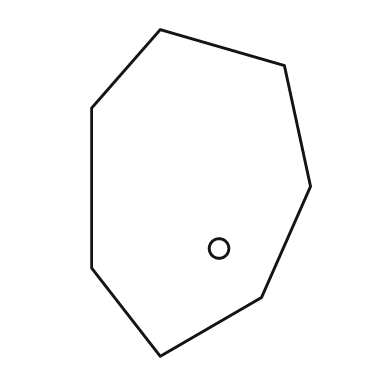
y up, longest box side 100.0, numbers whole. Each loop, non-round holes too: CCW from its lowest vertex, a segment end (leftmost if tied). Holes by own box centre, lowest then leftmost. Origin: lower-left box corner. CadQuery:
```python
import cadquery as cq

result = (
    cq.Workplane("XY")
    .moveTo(21.0, 0.0)
    .lineTo(52.0, 18.0)
    .lineTo(67.0, 52.0)
    .lineTo(59.0, 89.0)
    .lineTo(21.0, 100.0)
    .lineTo(0.0, 76.0)
    .lineTo(0.0, 27.0)
    .close()
    .moveTo(39.0, 33.0)
    .circle(3.0)
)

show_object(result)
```